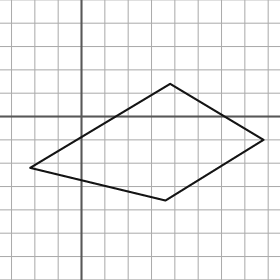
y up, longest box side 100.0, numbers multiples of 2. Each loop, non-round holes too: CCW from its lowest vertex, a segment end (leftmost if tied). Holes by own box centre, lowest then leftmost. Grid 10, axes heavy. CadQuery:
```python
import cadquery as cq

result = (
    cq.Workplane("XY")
    .moveTo(36.0, -36.0)
    .lineTo(78.0, -10.0)
    .lineTo(38.0, 14.0)
    .lineTo(-22.0, -22.0)
    .close()
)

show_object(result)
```